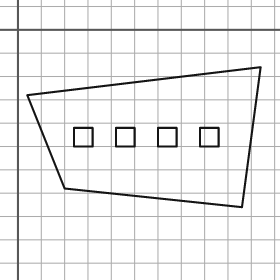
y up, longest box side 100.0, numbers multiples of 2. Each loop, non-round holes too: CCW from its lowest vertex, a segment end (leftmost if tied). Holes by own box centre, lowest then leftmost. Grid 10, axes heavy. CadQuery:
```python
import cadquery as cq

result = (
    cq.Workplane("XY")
    .moveTo(96.0, -76.0)
    .lineTo(104.0, -16.0)
    .lineTo(4.0, -28.0)
    .lineTo(20.0, -68.0)
    .close()
    .moveTo(24.0, -50.0)
    .lineTo(32.0, -50.0)
    .lineTo(32.0, -42.0)
    .lineTo(24.0, -42.0)
    .close()
    .moveTo(42.0, -50.0)
    .lineTo(50.0, -50.0)
    .lineTo(50.0, -42.0)
    .lineTo(42.0, -42.0)
    .close()
    .moveTo(60.0, -50.0)
    .lineTo(68.0, -50.0)
    .lineTo(68.0, -42.0)
    .lineTo(60.0, -42.0)
    .close()
    .moveTo(78.0, -50.0)
    .lineTo(86.0, -50.0)
    .lineTo(86.0, -42.0)
    .lineTo(78.0, -42.0)
    .close()
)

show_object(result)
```